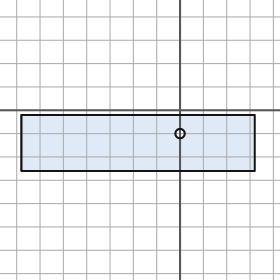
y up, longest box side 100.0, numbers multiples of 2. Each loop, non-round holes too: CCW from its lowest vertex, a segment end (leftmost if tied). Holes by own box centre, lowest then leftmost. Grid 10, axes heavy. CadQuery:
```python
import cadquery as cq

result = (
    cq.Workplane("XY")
    .moveTo(-68.0, -26.0)
    .lineTo(32.0, -26.0)
    .lineTo(32.0, -2.0)
    .lineTo(-68.0, -2.0)
    .close()
    .moveTo(0.0, -10.0)
    .circle(2.0)
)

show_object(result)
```